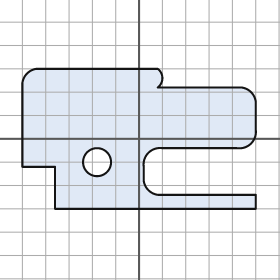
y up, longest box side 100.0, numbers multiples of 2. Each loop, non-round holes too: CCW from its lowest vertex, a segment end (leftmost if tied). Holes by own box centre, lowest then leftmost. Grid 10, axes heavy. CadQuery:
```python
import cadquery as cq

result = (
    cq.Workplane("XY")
    .moveTo(-36.0, -30.0)
    .lineTo(50.0, -30.0)
    .lineTo(50.0, -24.0)
    .lineTo(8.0, -24.0)
    .threePointArc((4.0, -22.0), (2.0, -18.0))
    .lineTo(2.0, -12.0)
    .threePointArc((4.0, -6.0), (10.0, -4.0))
    .lineTo(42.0, -4.0)
    .threePointArc((48.0, -2.0), (50.0, 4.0))
    .lineTo(50.0, 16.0)
    .threePointArc((48.0, 20.0), (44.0, 22.0))
    .lineTo(8.0, 22.0)
    .threePointArc((10.0, 26.0), (8.0, 30.0))
    .lineTo(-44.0, 30.0)
    .threePointArc((-48.0, 28.0), (-50.0, 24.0))
    .lineTo(-50.0, -12.0)
    .lineTo(-36.0, -12.0)
    .close()
    .moveTo(-18.0, -10.0)
    .circle(6.0)
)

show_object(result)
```